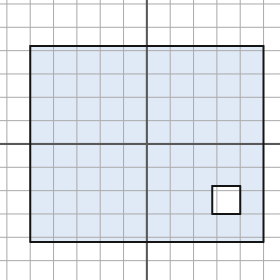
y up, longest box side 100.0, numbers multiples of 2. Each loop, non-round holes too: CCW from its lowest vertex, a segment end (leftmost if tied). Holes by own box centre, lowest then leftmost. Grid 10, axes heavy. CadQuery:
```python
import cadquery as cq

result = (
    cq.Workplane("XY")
    .moveTo(-50.0, -42.0)
    .lineTo(50.0, -42.0)
    .lineTo(50.0, 42.0)
    .lineTo(-50.0, 42.0)
    .close()
    .moveTo(28.0, -30.0)
    .lineTo(40.0, -30.0)
    .lineTo(40.0, -18.0)
    .lineTo(28.0, -18.0)
    .close()
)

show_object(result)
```